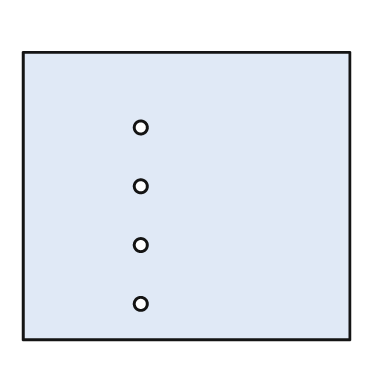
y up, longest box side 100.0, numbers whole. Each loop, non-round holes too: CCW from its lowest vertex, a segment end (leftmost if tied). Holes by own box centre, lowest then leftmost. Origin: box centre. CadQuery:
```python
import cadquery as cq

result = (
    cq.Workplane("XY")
    .moveTo(-50.0, -44.0)
    .lineTo(50.0, -44.0)
    .lineTo(50.0, 44.0)
    .lineTo(-50.0, 44.0)
    .close()
    .moveTo(-14.0, -33.0)
    .circle(2.0)
    .moveTo(-14.0, -15.0)
    .circle(2.0)
    .moveTo(-14.0, 3.0)
    .circle(2.0)
    .moveTo(-14.0, 21.0)
    .circle(2.0)
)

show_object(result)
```